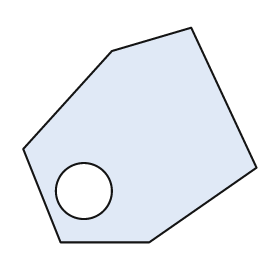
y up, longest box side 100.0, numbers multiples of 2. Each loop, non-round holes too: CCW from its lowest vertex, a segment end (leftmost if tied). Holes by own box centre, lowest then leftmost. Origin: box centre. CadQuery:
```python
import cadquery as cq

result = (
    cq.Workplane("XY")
    .moveTo(-34.0, -46.0)
    .lineTo(4.0, -46.0)
    .lineTo(50.0, -14.0)
    .lineTo(22.0, 46.0)
    .lineTo(-12.0, 36.0)
    .lineTo(-50.0, -6.0)
    .close()
    .moveTo(-24.0, -24.0)
    .circle(12.0)
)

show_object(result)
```